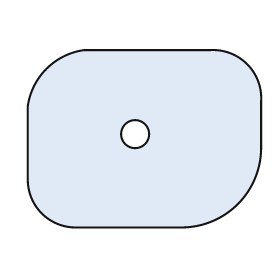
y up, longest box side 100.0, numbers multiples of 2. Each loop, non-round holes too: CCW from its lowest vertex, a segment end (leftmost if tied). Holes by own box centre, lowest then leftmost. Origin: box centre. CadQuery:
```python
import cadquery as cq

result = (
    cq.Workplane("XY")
    .moveTo(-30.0, -38.0)
    .lineTo(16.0, -38.0)
    .threePointArc((40.0, -28.0), (50.0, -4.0))
    .lineTo(50.0, 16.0)
    .threePointArc((44.0, 32.0), (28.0, 38.0))
    .lineTo(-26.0, 38.0)
    .threePointArc((-42.0, 30.0), (-50.0, 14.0))
    .lineTo(-50.0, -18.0)
    .threePointArc((-44.0, -32.0), (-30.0, -38.0))
    .close()
    .moveTo(-4.0, 2.0)
    .circle(6.0)
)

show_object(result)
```